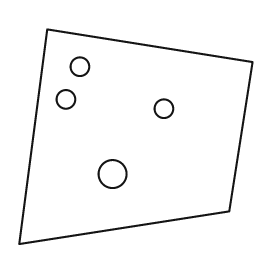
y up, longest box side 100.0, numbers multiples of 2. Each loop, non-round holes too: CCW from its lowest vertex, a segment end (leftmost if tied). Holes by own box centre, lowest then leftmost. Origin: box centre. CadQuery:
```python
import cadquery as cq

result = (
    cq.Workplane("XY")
    .moveTo(-50.0, -46.0)
    .lineTo(40.0, -32.0)
    .lineTo(50.0, 32.0)
    .lineTo(-38.0, 46.0)
    .close()
    .moveTo(-10.0, -16.0)
    .circle(6.0)
    .moveTo(12.0, 12.0)
    .circle(4.0)
    .moveTo(-30.0, 16.0)
    .circle(4.0)
    .moveTo(-24.0, 30.0)
    .circle(4.0)
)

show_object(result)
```